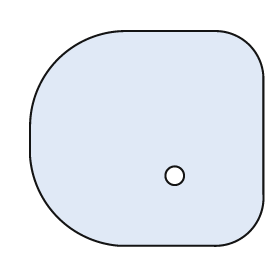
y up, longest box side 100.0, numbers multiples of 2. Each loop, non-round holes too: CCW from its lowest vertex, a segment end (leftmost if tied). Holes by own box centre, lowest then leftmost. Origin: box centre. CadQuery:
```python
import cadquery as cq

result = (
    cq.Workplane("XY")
    .moveTo(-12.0, -46.0)
    .lineTo(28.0, -46.0)
    .threePointArc((44.0, -40.0), (50.0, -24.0))
    .lineTo(50.0, 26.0)
    .threePointArc((44.0, 40.0), (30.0, 46.0))
    .lineTo(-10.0, 46.0)
    .threePointArc((-38.0, 34.0), (-50.0, 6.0))
    .lineTo(-50.0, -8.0)
    .threePointArc((-38.0, -34.0), (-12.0, -46.0))
    .close()
    .moveTo(12.0, -16.0)
    .circle(4.0)
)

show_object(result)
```